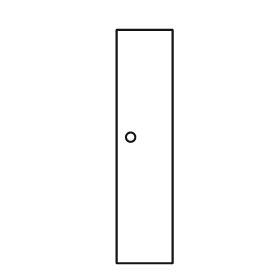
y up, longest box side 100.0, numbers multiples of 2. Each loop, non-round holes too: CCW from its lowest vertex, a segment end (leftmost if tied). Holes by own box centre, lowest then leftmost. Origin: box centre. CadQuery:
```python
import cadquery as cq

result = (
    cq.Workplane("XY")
    .moveTo(-12.0, -50.0)
    .lineTo(12.0, -50.0)
    .lineTo(12.0, 50.0)
    .lineTo(-12.0, 50.0)
    .close()
    .moveTo(-6.0, 4.0)
    .circle(2.0)
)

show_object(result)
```